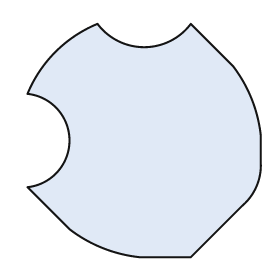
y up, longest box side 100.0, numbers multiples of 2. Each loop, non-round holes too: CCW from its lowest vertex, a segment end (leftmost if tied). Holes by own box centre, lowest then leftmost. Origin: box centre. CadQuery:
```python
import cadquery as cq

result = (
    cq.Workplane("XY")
    .moveTo(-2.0, -50.0)
    .lineTo(20.0, -50.0)
    .lineTo(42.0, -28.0)
    .threePointArc((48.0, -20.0), (50.0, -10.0))
    .lineTo(50.0, 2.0)
    .threePointArc((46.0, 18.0), (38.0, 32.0))
    .lineTo(20.0, 50.0)
    .threePointArc((0.0, 40.0), (-20.0, 50.0))
    .threePointArc((-38.0, 38.0), (-50.0, 20.0))
    .threePointArc((-32.0, 0.0), (-50.0, -20.0))
    .lineTo(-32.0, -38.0)
    .threePointArc((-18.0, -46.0), (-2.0, -50.0))
    .close()
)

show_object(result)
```